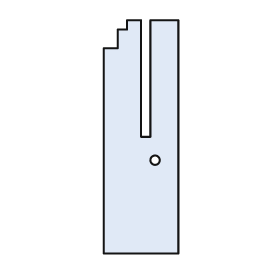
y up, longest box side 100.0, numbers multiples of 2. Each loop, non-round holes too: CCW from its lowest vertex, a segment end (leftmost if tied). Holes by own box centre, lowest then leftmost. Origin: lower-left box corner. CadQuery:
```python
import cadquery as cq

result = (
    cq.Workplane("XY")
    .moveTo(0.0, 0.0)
    .lineTo(32.0, 0.0)
    .lineTo(32.0, 100.0)
    .lineTo(20.0, 100.0)
    .lineTo(20.0, 50.0)
    .lineTo(16.0, 50.0)
    .lineTo(16.0, 100.0)
    .lineTo(10.0, 100.0)
    .lineTo(10.0, 96.0)
    .lineTo(6.0, 96.0)
    .lineTo(6.0, 88.0)
    .lineTo(0.0, 88.0)
    .close()
    .moveTo(22.0, 40.0)
    .circle(2.0)
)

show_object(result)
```